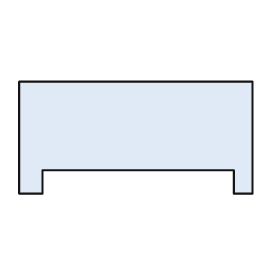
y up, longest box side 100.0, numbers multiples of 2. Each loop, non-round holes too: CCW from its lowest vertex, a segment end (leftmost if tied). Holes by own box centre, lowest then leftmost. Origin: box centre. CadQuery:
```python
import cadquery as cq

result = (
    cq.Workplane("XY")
    .moveTo(-50.0, -24.0)
    .lineTo(-40.0, -24.0)
    .lineTo(-40.0, -14.0)
    .lineTo(42.0, -14.0)
    .lineTo(42.0, -24.0)
    .lineTo(50.0, -24.0)
    .lineTo(50.0, 24.0)
    .lineTo(-50.0, 24.0)
    .close()
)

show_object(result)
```